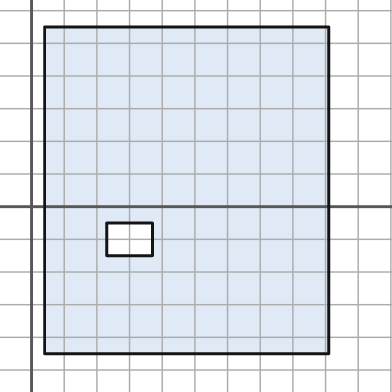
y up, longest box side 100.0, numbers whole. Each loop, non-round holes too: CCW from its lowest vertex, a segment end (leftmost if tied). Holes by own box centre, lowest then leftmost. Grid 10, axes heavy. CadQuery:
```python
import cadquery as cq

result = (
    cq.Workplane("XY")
    .moveTo(4.0, -45.0)
    .lineTo(91.0, -45.0)
    .lineTo(91.0, 55.0)
    .lineTo(4.0, 55.0)
    .close()
    .moveTo(23.0, -15.0)
    .lineTo(37.0, -15.0)
    .lineTo(37.0, -5.0)
    .lineTo(23.0, -5.0)
    .close()
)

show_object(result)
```